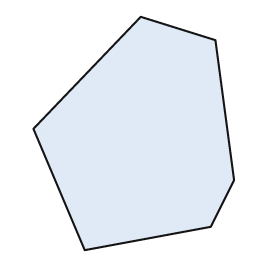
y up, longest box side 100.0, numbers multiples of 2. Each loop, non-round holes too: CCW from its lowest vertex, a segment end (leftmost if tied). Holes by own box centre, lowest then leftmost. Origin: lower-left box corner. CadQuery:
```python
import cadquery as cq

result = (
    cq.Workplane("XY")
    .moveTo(22.0, 0.0)
    .lineTo(76.0, 10.0)
    .lineTo(86.0, 30.0)
    .lineTo(78.0, 90.0)
    .lineTo(46.0, 100.0)
    .lineTo(0.0, 52.0)
    .close()
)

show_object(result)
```